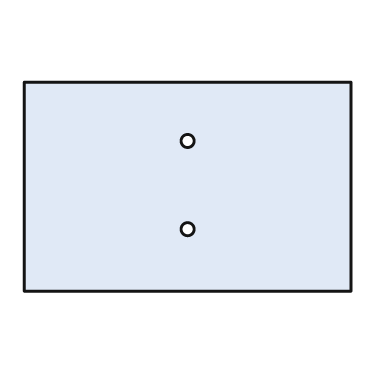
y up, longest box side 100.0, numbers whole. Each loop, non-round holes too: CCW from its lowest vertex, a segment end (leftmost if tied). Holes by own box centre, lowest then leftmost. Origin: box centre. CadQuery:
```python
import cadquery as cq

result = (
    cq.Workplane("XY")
    .moveTo(-50.0, -32.0)
    .lineTo(50.0, -32.0)
    .lineTo(50.0, 32.0)
    .lineTo(-50.0, 32.0)
    .close()
    .moveTo(0.0, -13.0)
    .circle(2.0)
    .moveTo(0.0, 14.0)
    .circle(2.0)
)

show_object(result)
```